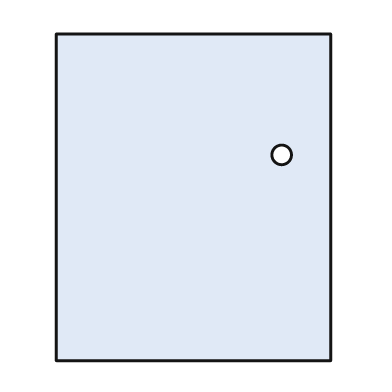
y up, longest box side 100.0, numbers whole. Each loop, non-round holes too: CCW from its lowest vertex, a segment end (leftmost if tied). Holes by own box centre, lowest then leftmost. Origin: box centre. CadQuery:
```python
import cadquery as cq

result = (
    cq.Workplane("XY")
    .moveTo(-42.0, -50.0)
    .lineTo(42.0, -50.0)
    .lineTo(42.0, 50.0)
    .lineTo(-42.0, 50.0)
    .close()
    .moveTo(27.0, 13.0)
    .circle(3.0)
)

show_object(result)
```